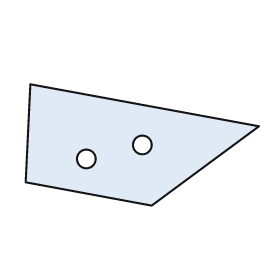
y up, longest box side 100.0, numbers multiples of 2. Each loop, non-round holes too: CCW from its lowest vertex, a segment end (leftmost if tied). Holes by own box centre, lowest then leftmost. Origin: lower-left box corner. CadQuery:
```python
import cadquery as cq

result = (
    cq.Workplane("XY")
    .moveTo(54.0, 0.0)
    .lineTo(100.0, 34.0)
    .lineTo(2.0, 52.0)
    .lineTo(0.0, 10.0)
    .close()
    .moveTo(26.0, 20.0)
    .circle(4.0)
    .moveTo(50.0, 26.0)
    .circle(4.0)
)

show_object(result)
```